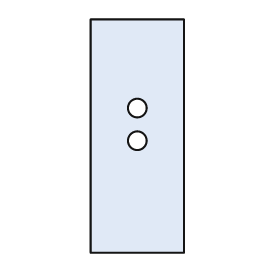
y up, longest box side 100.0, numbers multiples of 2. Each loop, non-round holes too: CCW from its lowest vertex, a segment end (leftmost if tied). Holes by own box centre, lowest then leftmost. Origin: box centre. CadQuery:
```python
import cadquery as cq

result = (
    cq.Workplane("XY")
    .moveTo(-20.0, -50.0)
    .lineTo(20.0, -50.0)
    .lineTo(20.0, 50.0)
    .lineTo(-20.0, 50.0)
    .close()
    .moveTo(0.0, -2.0)
    .circle(4.0)
    .moveTo(0.0, 12.0)
    .circle(4.0)
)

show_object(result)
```